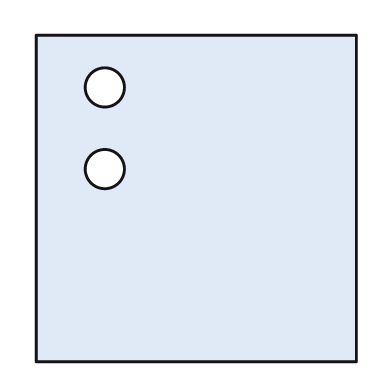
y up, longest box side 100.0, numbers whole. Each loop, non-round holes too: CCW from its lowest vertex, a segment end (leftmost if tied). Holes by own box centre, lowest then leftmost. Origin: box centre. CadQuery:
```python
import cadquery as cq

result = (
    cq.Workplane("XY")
    .moveTo(-49.0, -50.0)
    .lineTo(49.0, -50.0)
    .lineTo(49.0, 50.0)
    .lineTo(-49.0, 50.0)
    .close()
    .moveTo(-28.0, 9.0)
    .circle(6.0)
    .moveTo(-28.0, 34.0)
    .circle(6.0)
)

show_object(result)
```